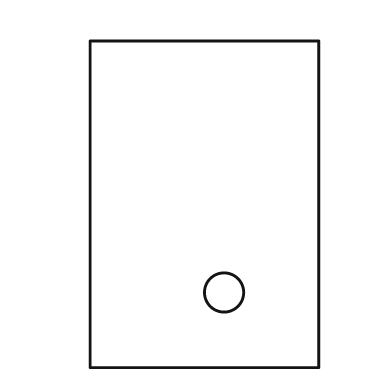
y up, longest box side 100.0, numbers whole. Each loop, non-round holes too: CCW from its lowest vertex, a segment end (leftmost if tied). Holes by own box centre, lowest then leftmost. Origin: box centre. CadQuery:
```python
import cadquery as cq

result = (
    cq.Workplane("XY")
    .moveTo(-35.0, -50.0)
    .lineTo(35.0, -50.0)
    .lineTo(35.0, 50.0)
    .lineTo(-35.0, 50.0)
    .close()
    .moveTo(6.0, -27.0)
    .circle(6.0)
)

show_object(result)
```